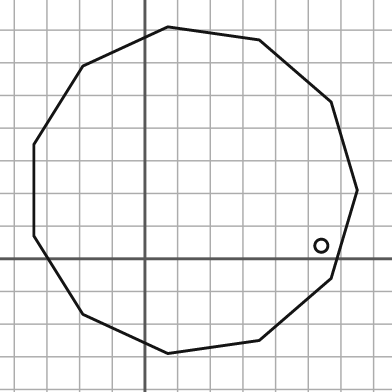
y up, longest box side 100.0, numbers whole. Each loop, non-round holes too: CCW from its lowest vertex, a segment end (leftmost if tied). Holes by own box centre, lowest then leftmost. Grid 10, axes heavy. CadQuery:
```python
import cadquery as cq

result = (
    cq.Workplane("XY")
    .moveTo(7.0, -29.0)
    .lineTo(35.0, -25.0)
    .lineTo(57.0, -6.0)
    .lineTo(65.0, 21.0)
    .lineTo(57.0, 48.0)
    .lineTo(35.0, 67.0)
    .lineTo(7.0, 71.0)
    .lineTo(-19.0, 59.0)
    .lineTo(-34.0, 35.0)
    .lineTo(-34.0, 7.0)
    .lineTo(-19.0, -17.0)
    .close()
    .moveTo(54.0, 4.0)
    .circle(2.0)
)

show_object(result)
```